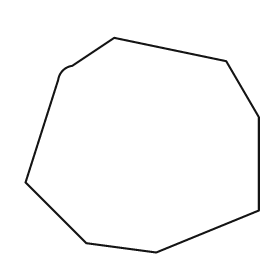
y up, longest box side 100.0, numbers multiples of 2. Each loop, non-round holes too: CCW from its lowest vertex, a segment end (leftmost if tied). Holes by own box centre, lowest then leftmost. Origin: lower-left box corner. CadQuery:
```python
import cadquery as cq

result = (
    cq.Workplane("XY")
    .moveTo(56.0, 0.0)
    .lineTo(100.0, 18.0)
    .lineTo(100.0, 58.0)
    .lineTo(86.0, 82.0)
    .lineTo(38.0, 92.0)
    .lineTo(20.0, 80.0)
    .threePointArc((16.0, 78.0), (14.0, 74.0))
    .lineTo(0.0, 30.0)
    .lineTo(26.0, 4.0)
    .close()
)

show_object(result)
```